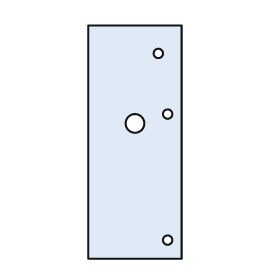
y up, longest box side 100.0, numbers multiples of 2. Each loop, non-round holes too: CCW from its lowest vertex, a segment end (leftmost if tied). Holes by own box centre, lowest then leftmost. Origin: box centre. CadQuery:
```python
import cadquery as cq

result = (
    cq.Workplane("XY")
    .moveTo(-20.0, -50.0)
    .lineTo(20.0, -50.0)
    .lineTo(20.0, 50.0)
    .lineTo(-20.0, 50.0)
    .close()
    .moveTo(14.0, -42.0)
    .circle(2.0)
    .moveTo(0.0, 8.0)
    .circle(4.0)
    .moveTo(14.0, 12.0)
    .circle(2.0)
    .moveTo(10.0, 38.0)
    .circle(2.0)
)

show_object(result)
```